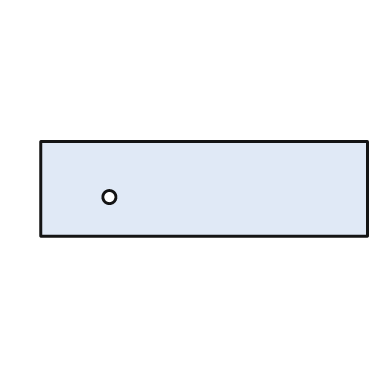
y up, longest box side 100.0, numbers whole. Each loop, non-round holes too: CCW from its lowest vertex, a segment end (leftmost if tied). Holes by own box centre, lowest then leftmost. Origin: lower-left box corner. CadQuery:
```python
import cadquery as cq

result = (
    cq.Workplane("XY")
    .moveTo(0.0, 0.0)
    .lineTo(100.0, 0.0)
    .lineTo(100.0, 29.0)
    .lineTo(0.0, 29.0)
    .close()
    .moveTo(21.0, 12.0)
    .circle(2.0)
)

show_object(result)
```